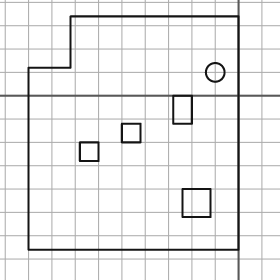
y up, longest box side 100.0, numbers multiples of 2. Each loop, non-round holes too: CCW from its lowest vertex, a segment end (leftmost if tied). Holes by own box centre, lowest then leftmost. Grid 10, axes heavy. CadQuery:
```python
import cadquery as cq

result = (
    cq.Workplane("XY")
    .moveTo(-90.0, -66.0)
    .lineTo(0.0, -66.0)
    .lineTo(0.0, 34.0)
    .lineTo(-72.0, 34.0)
    .lineTo(-72.0, 12.0)
    .lineTo(-90.0, 12.0)
    .close()
    .moveTo(-24.0, -52.0)
    .lineTo(-12.0, -52.0)
    .lineTo(-12.0, -40.0)
    .lineTo(-24.0, -40.0)
    .close()
    .moveTo(-68.0, -28.0)
    .lineTo(-60.0, -28.0)
    .lineTo(-60.0, -20.0)
    .lineTo(-68.0, -20.0)
    .close()
    .moveTo(-50.0, -20.0)
    .lineTo(-42.0, -20.0)
    .lineTo(-42.0, -12.0)
    .lineTo(-50.0, -12.0)
    .close()
    .moveTo(-28.0, -12.0)
    .lineTo(-20.0, -12.0)
    .lineTo(-20.0, 0.0)
    .lineTo(-28.0, 0.0)
    .close()
    .moveTo(-10.0, 10.0)
    .circle(4.0)
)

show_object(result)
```